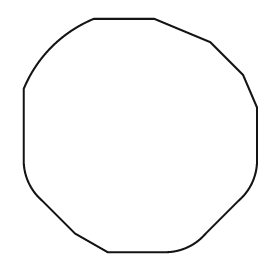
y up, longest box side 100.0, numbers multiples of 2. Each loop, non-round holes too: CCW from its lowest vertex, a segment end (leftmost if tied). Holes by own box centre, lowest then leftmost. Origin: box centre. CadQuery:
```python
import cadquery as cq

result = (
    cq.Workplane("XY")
    .moveTo(-14.0, -50.0)
    .lineTo(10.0, -50.0)
    .threePointArc((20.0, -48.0), (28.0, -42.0))
    .lineTo(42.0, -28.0)
    .threePointArc((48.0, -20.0), (50.0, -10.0))
    .lineTo(50.0, 12.0)
    .lineTo(44.0, 26.0)
    .lineTo(30.0, 40.0)
    .lineTo(6.0, 50.0)
    .lineTo(-20.0, 50.0)
    .threePointArc((-38.0, 38.0), (-50.0, 20.0))
    .lineTo(-50.0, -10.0)
    .threePointArc((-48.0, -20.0), (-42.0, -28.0))
    .lineTo(-28.0, -42.0)
    .close()
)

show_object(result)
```